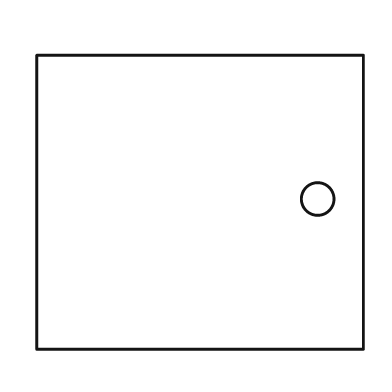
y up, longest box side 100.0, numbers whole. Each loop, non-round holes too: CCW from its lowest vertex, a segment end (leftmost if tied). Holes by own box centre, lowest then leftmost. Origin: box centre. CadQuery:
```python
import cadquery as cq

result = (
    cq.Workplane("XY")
    .moveTo(-50.0, -45.0)
    .lineTo(50.0, -45.0)
    .lineTo(50.0, 45.0)
    .lineTo(-50.0, 45.0)
    .close()
    .moveTo(36.0, 1.0)
    .circle(5.0)
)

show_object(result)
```